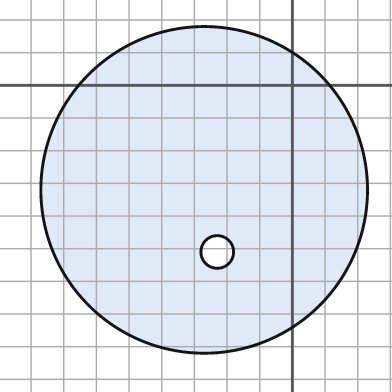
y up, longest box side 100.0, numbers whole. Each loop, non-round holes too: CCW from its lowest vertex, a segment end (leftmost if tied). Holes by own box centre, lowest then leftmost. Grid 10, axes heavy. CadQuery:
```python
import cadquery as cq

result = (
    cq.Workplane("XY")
    .moveTo(-27.0, -32.0)
    .circle(50.0)
    .moveTo(-23.0, -51.0)
    .circle(5.0)
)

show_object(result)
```